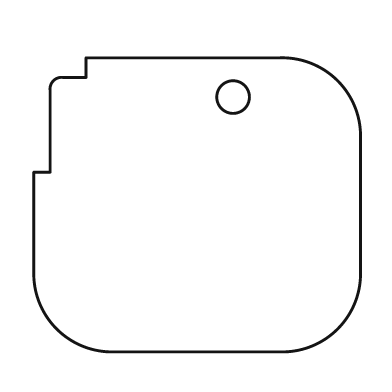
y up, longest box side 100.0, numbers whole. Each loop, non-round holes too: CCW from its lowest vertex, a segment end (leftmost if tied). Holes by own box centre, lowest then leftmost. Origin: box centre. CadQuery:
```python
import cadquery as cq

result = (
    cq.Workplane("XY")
    .moveTo(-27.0, -45.0)
    .lineTo(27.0, -45.0)
    .threePointArc((43.0, -38.0), (50.0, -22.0))
    .lineTo(50.0, 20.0)
    .threePointArc((43.0, 38.0), (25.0, 45.0))
    .lineTo(-34.0, 45.0)
    .lineTo(-34.0, 39.0)
    .lineTo(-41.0, 39.0)
    .threePointArc((-44.0, 38.0), (-45.0, 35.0))
    .lineTo(-45.0, 10.0)
    .lineTo(-50.0, 10.0)
    .lineTo(-50.0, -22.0)
    .threePointArc((-43.0, -38.0), (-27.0, -45.0))
    .close()
    .moveTo(11.0, 33.0)
    .circle(5.0)
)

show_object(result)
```